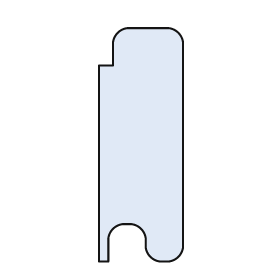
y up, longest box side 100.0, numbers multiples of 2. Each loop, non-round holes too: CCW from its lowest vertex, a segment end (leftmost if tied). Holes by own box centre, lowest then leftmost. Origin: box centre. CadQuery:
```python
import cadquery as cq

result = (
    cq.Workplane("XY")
    .moveTo(-18.0, -50.0)
    .lineTo(-14.0, -50.0)
    .lineTo(-14.0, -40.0)
    .threePointArc((-12.0, -36.0), (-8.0, -34.0))
    .lineTo(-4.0, -34.0)
    .threePointArc((0.0, -36.0), (2.0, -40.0))
    .lineTo(2.0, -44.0)
    .threePointArc((4.0, -48.0), (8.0, -50.0))
    .lineTo(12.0, -50.0)
    .threePointArc((16.0, -48.0), (18.0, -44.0))
    .lineTo(18.0, 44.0)
    .threePointArc((16.0, 48.0), (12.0, 50.0))
    .lineTo(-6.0, 50.0)
    .threePointArc((-10.0, 48.0), (-12.0, 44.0))
    .lineTo(-12.0, 34.0)
    .lineTo(-18.0, 34.0)
    .close()
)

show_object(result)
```